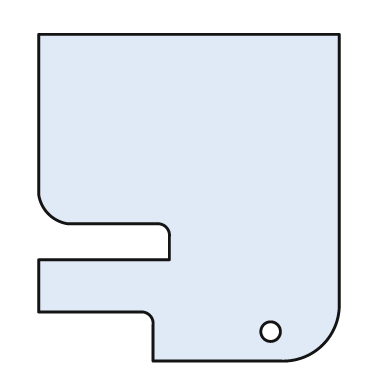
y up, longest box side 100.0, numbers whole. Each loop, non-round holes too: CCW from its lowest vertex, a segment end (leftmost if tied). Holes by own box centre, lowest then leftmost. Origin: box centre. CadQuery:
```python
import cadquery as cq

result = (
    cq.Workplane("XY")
    .moveTo(-11.0, -50.0)
    .lineTo(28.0, -50.0)
    .threePointArc((41.0, -45.0), (46.0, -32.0))
    .lineTo(46.0, 50.0)
    .lineTo(-46.0, 50.0)
    .lineTo(-46.0, 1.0)
    .threePointArc((-43.0, -5.0), (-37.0, -8.0))
    .lineTo(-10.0, -8.0)
    .threePointArc((-7.0, -9.0), (-6.0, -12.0))
    .lineTo(-6.0, -19.0)
    .lineTo(-46.0, -19.0)
    .lineTo(-46.0, -35.0)
    .lineTo(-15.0, -35.0)
    .threePointArc((-12.0, -36.0), (-11.0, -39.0))
    .close()
    .moveTo(25.0, -41.0)
    .circle(3.0)
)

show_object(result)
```